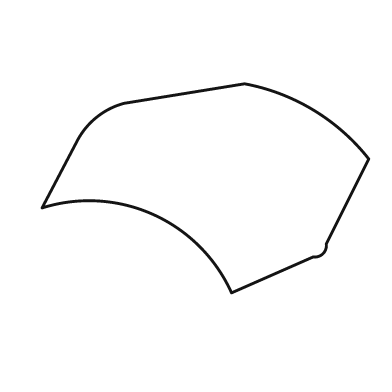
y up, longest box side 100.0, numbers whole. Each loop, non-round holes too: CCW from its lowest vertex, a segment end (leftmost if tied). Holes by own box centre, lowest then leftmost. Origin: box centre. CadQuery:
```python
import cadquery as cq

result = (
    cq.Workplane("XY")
    .moveTo(8.0, -32.0)
    .lineTo(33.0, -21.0)
    .threePointArc((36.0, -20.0), (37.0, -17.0))
    .lineTo(50.0, 9.0)
    .threePointArc((33.0, 24.0), (12.0, 32.0))
    .lineTo(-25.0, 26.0)
    .threePointArc((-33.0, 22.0), (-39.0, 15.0))
    .lineTo(-50.0, -6.0)
    .threePointArc((-16.0, -8.0), (8.0, -32.0))
    .close()
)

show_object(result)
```